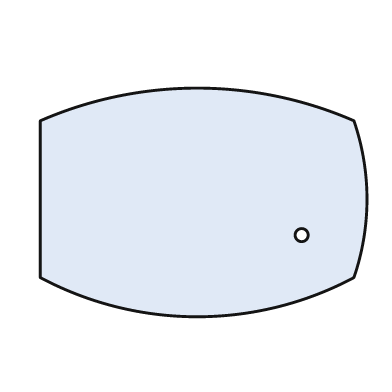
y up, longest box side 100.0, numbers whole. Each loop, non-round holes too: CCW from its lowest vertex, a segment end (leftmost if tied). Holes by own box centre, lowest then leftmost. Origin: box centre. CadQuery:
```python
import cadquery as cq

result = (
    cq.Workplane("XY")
    .moveTo(-50.0, -23.0)
    .threePointArc((-2.0, -35.0), (46.0, -23.0))
    .threePointArc((50.0, 1.0), (46.0, 25.0))
    .threePointArc((-2.0, 35.0), (-50.0, 25.0))
    .close()
    .moveTo(30.0, -10.0)
    .circle(2.0)
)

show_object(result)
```